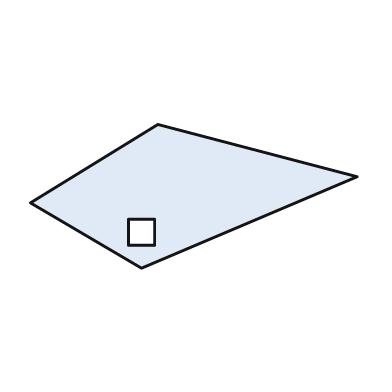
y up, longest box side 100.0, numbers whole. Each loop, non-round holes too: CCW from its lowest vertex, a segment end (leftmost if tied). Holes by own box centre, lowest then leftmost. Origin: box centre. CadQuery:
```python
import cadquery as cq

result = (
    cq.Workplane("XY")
    .moveTo(-16.0, -22.0)
    .lineTo(50.0, 6.0)
    .lineTo(-11.0, 22.0)
    .lineTo(-50.0, -2.0)
    .close()
    .moveTo(-20.0, -15.0)
    .lineTo(-12.0, -15.0)
    .lineTo(-12.0, -7.0)
    .lineTo(-20.0, -7.0)
    .close()
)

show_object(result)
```